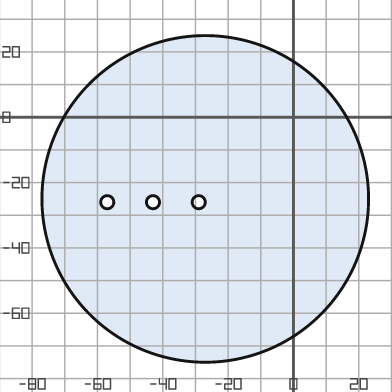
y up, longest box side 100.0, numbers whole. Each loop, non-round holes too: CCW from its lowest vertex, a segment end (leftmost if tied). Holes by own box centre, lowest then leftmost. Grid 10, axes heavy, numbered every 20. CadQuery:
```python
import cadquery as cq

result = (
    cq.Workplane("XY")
    .moveTo(-27.0, -25.0)
    .circle(50.0)
    .moveTo(-57.0, -26.0)
    .circle(2.0)
    .moveTo(-43.0, -26.0)
    .circle(2.0)
    .moveTo(-29.0, -26.0)
    .circle(2.0)
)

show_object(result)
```